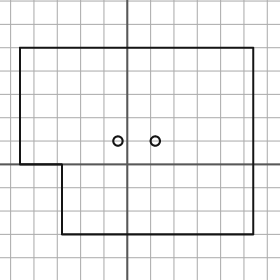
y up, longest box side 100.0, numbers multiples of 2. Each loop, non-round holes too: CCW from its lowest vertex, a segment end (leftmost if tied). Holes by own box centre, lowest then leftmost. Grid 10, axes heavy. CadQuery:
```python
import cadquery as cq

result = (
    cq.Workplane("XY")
    .moveTo(-28.0, -30.0)
    .lineTo(54.0, -30.0)
    .lineTo(54.0, 50.0)
    .lineTo(-46.0, 50.0)
    .lineTo(-46.0, 0.0)
    .lineTo(-28.0, 0.0)
    .close()
    .moveTo(-4.0, 10.0)
    .circle(2.0)
    .moveTo(12.0, 10.0)
    .circle(2.0)
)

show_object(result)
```